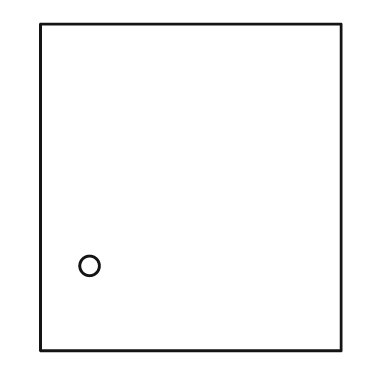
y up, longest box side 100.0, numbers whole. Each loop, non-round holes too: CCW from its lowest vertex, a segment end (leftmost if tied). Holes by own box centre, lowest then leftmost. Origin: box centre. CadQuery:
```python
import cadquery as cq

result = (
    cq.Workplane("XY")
    .moveTo(-46.0, -50.0)
    .lineTo(46.0, -50.0)
    .lineTo(46.0, 50.0)
    .lineTo(-46.0, 50.0)
    .close()
    .moveTo(-31.0, -24.0)
    .circle(3.0)
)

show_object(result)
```